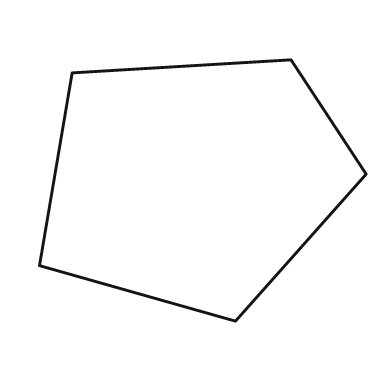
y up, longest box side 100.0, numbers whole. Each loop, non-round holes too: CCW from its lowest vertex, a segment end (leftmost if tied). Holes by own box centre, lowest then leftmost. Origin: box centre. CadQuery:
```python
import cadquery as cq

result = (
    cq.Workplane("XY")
    .moveTo(10.0, -40.0)
    .lineTo(50.0, 5.0)
    .lineTo(27.0, 40.0)
    .lineTo(-40.0, 36.0)
    .lineTo(-50.0, -23.0)
    .close()
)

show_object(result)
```